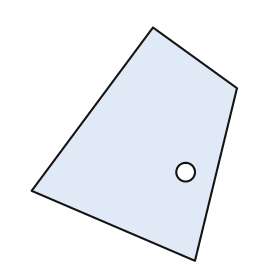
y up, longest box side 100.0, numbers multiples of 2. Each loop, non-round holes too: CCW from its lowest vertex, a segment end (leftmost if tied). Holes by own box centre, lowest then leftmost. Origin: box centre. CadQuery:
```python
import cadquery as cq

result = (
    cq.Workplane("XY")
    .moveTo(26.0, -50.0)
    .lineTo(44.0, 24.0)
    .lineTo(8.0, 50.0)
    .lineTo(-44.0, -20.0)
    .close()
    .moveTo(22.0, -12.0)
    .circle(4.0)
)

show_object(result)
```